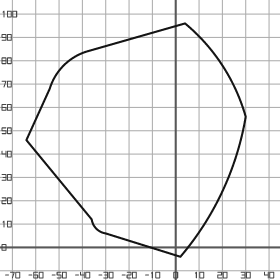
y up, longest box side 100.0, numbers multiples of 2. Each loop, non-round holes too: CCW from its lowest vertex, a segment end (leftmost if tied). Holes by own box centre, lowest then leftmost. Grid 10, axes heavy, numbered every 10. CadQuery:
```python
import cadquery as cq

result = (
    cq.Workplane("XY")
    .moveTo(2.0, -4.0)
    .threePointArc((20.0, 24.0), (30.0, 56.0))
    .threePointArc((20.0, 78.0), (4.0, 96.0))
    .lineTo(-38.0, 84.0)
    .threePointArc((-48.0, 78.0), (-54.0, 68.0))
    .lineTo(-64.0, 46.0)
    .lineTo(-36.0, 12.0)
    .threePointArc((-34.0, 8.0), (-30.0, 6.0))
    .close()
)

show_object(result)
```